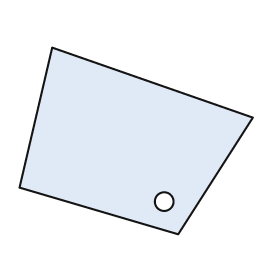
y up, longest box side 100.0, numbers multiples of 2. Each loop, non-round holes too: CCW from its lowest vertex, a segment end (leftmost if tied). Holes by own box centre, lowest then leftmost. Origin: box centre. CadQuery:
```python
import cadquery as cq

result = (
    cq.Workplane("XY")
    .moveTo(18.0, -40.0)
    .lineTo(50.0, 10.0)
    .lineTo(-36.0, 40.0)
    .lineTo(-50.0, -20.0)
    .close()
    .moveTo(12.0, -26.0)
    .circle(4.0)
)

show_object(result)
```